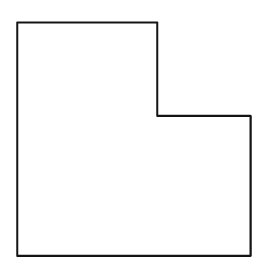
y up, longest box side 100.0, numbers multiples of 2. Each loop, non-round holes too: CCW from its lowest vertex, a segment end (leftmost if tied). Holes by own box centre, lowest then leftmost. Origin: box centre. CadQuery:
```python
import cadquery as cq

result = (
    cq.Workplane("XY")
    .moveTo(-50.0, -50.0)
    .lineTo(50.0, -50.0)
    .lineTo(50.0, 10.0)
    .lineTo(10.0, 10.0)
    .lineTo(10.0, 50.0)
    .lineTo(-50.0, 50.0)
    .close()
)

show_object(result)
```